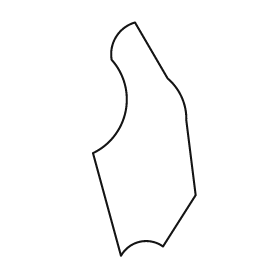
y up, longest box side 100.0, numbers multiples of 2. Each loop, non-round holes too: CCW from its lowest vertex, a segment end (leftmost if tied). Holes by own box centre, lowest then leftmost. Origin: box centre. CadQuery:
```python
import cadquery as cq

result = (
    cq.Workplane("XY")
    .moveTo(-10.0, -50.0)
    .threePointArc((-2.0, -44.0), (8.0, -46.0))
    .lineTo(22.0, -24.0)
    .lineTo(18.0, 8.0)
    .threePointArc((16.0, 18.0), (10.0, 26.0))
    .lineTo(-4.0, 50.0)
    .threePointArc((-12.0, 44.0), (-14.0, 34.0))
    .threePointArc((-8.0, 12.0), (-22.0, -6.0))
    .close()
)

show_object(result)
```